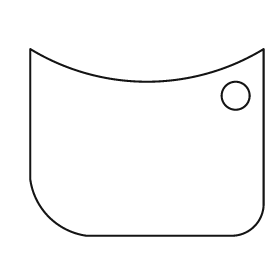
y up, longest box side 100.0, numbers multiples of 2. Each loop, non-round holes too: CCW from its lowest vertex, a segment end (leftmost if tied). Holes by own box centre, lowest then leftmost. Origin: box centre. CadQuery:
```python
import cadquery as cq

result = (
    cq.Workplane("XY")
    .moveTo(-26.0, -40.0)
    .lineTo(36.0, -40.0)
    .threePointArc((46.0, -36.0), (50.0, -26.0))
    .lineTo(50.0, 40.0)
    .threePointArc((0.0, 26.0), (-50.0, 40.0))
    .lineTo(-50.0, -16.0)
    .threePointArc((-42.0, -32.0), (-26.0, -40.0))
    .close()
    .moveTo(38.0, 20.0)
    .circle(6.0)
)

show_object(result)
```